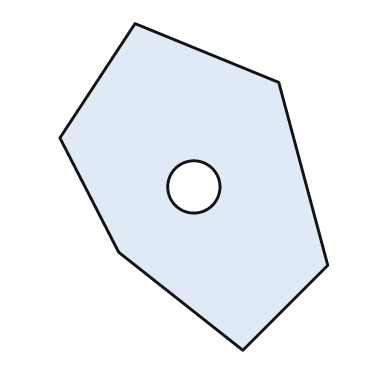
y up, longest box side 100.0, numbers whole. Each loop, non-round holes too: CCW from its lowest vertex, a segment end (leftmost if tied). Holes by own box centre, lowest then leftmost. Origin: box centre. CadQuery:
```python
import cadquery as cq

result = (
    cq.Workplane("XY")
    .moveTo(15.0, -50.0)
    .lineTo(41.0, -24.0)
    .lineTo(26.0, 32.0)
    .lineTo(-18.0, 50.0)
    .lineTo(-41.0, 15.0)
    .lineTo(-23.0, -20.0)
    .close()
    .moveTo(0.0, 0.0)
    .circle(8.0)
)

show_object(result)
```